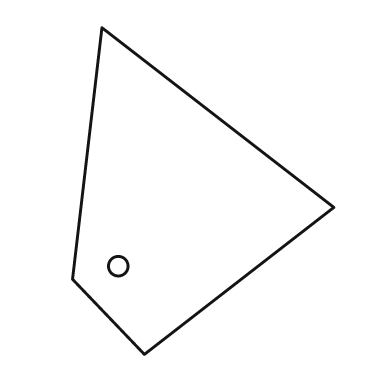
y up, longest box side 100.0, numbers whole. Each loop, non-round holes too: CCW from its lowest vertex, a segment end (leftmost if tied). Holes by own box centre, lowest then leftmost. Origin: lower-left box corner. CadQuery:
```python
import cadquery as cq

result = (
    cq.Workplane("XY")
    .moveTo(22.0, 0.0)
    .lineTo(80.0, 45.0)
    .lineTo(9.0, 100.0)
    .lineTo(0.0, 23.0)
    .close()
    .moveTo(14.0, 27.0)
    .circle(3.0)
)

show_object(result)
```